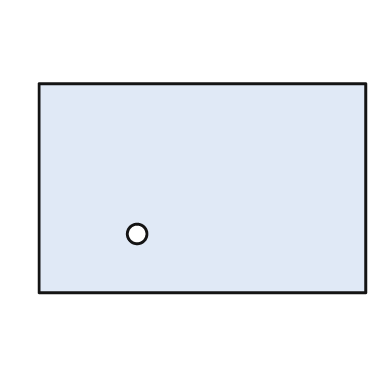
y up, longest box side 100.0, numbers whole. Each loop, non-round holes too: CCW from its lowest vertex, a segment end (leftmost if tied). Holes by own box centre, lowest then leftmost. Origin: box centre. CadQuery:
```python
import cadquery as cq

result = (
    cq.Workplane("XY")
    .moveTo(-50.0, -32.0)
    .lineTo(50.0, -32.0)
    .lineTo(50.0, 32.0)
    .lineTo(-50.0, 32.0)
    .close()
    .moveTo(-20.0, -14.0)
    .circle(3.0)
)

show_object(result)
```